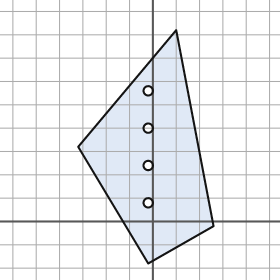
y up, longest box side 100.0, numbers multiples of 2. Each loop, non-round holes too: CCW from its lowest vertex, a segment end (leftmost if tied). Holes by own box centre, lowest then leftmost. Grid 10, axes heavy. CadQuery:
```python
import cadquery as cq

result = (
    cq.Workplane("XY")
    .moveTo(-2.0, -18.0)
    .lineTo(26.0, -2.0)
    .lineTo(10.0, 82.0)
    .lineTo(-32.0, 32.0)
    .close()
    .moveTo(-2.0, 8.0)
    .circle(2.0)
    .moveTo(-2.0, 24.0)
    .circle(2.0)
    .moveTo(-2.0, 40.0)
    .circle(2.0)
    .moveTo(-2.0, 56.0)
    .circle(2.0)
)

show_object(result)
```